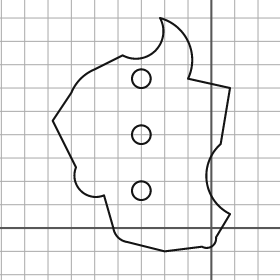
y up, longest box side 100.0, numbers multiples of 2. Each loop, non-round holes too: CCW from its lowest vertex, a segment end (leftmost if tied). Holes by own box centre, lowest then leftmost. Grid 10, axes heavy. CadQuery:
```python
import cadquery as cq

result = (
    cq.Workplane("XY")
    .moveTo(-20.0, -10.0)
    .lineTo(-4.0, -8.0)
    .threePointArc((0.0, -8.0), (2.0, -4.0))
    .lineTo(8.0, 6.0)
    .threePointArc((-2.0, 20.0), (4.0, 36.0))
    .lineTo(8.0, 60.0)
    .lineTo(-10.0, 64.0)
    .threePointArc((-10.0, 80.0), (-22.0, 90.0))
    .threePointArc((-24.0, 76.0), (-38.0, 74.0))
    .lineTo(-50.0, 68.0)
    .threePointArc((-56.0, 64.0), (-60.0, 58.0))
    .lineTo(-68.0, 46.0)
    .lineTo(-58.0, 26.0)
    .threePointArc((-56.0, 16.0), (-46.0, 14.0))
    .lineTo(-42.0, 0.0)
    .threePointArc((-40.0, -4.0), (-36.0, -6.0))
    .close()
    .moveTo(-30.0, 16.0)
    .circle(4.0)
    .moveTo(-30.0, 40.0)
    .circle(4.0)
    .moveTo(-30.0, 64.0)
    .circle(4.0)
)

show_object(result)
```